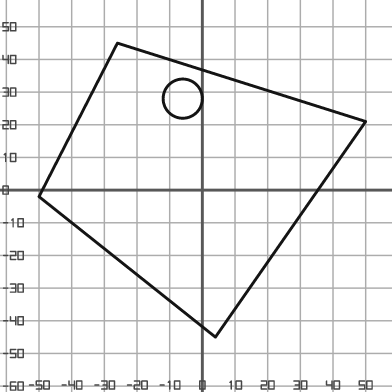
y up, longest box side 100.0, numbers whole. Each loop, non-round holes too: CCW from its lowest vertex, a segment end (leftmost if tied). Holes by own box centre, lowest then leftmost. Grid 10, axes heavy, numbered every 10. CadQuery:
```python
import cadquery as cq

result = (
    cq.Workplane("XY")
    .moveTo(4.0, -45.0)
    .lineTo(50.0, 21.0)
    .lineTo(-26.0, 45.0)
    .lineTo(-50.0, -2.0)
    .close()
    .moveTo(-6.0, 28.0)
    .circle(6.0)
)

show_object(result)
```